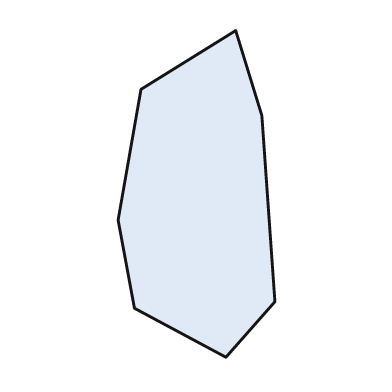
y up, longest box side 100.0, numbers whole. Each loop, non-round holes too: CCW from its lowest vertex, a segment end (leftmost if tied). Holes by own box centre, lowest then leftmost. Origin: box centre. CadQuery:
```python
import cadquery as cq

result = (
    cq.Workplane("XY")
    .moveTo(9.0, -50.0)
    .lineTo(24.0, -33.0)
    .lineTo(20.0, 24.0)
    .lineTo(12.0, 50.0)
    .lineTo(-17.0, 32.0)
    .lineTo(-24.0, -8.0)
    .lineTo(-19.0, -35.0)
    .close()
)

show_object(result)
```